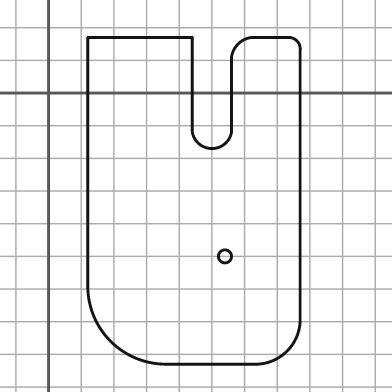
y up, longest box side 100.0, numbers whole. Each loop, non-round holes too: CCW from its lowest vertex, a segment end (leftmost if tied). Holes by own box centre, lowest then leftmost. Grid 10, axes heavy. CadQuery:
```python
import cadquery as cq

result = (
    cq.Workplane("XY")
    .moveTo(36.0, -83.0)
    .lineTo(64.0, -83.0)
    .threePointArc((73.0, -79.0), (77.0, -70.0))
    .lineTo(77.0, 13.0)
    .threePointArc((76.0, 16.0), (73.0, 17.0))
    .lineTo(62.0, 17.0)
    .threePointArc((58.0, 15.0), (56.0, 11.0))
    .lineTo(56.0, -12.0)
    .threePointArc((50.0, -17.0), (44.0, -12.0))
    .lineTo(44.0, 17.0)
    .lineTo(12.0, 17.0)
    .lineTo(12.0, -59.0)
    .threePointArc((19.0, -76.0), (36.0, -83.0))
    .close()
    .moveTo(54.0, -50.0)
    .circle(2.0)
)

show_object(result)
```